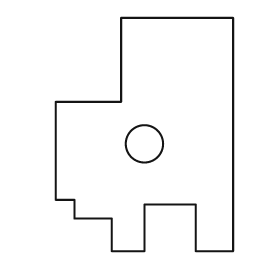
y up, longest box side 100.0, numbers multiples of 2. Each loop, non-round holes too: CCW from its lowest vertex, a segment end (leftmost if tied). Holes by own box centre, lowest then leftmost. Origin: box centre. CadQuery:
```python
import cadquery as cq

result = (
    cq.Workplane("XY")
    .moveTo(-14.0, -50.0)
    .lineTo(0.0, -50.0)
    .lineTo(0.0, -30.0)
    .lineTo(22.0, -30.0)
    .lineTo(22.0, -50.0)
    .lineTo(38.0, -50.0)
    .lineTo(38.0, 50.0)
    .lineTo(-10.0, 50.0)
    .lineTo(-10.0, 14.0)
    .lineTo(-38.0, 14.0)
    .lineTo(-38.0, -28.0)
    .lineTo(-30.0, -28.0)
    .lineTo(-30.0, -36.0)
    .lineTo(-14.0, -36.0)
    .close()
    .moveTo(0.0, -4.0)
    .circle(8.0)
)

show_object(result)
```